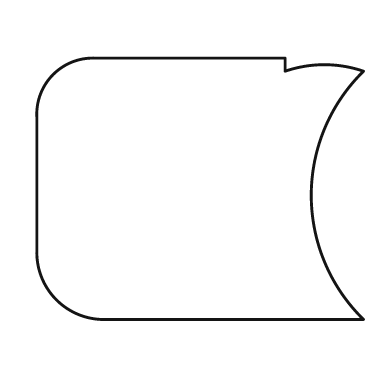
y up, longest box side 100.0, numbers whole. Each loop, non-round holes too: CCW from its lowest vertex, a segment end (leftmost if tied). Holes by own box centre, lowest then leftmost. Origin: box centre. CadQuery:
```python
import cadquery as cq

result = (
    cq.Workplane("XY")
    .moveTo(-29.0, -40.0)
    .lineTo(50.0, -40.0)
    .threePointArc((34.0, -2.0), (50.0, 36.0))
    .threePointArc((38.0, 38.0), (26.0, 36.0))
    .lineTo(26.0, 40.0)
    .lineTo(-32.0, 40.0)
    .threePointArc((-45.0, 35.0), (-50.0, 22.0))
    .lineTo(-50.0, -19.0)
    .threePointArc((-44.0, -34.0), (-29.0, -40.0))
    .close()
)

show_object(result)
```